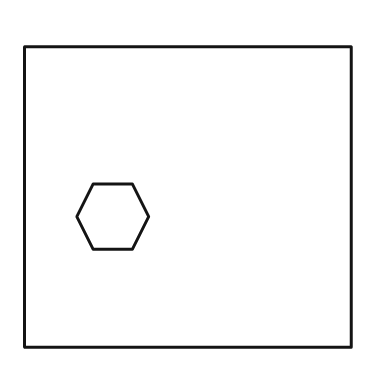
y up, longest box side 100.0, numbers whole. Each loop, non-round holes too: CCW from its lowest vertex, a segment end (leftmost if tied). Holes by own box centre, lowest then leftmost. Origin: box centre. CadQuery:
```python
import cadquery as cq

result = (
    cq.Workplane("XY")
    .moveTo(-50.0, -46.0)
    .lineTo(50.0, -46.0)
    .lineTo(50.0, 46.0)
    .lineTo(-50.0, 46.0)
    .close()
    .moveTo(-29.0, -16.0)
    .lineTo(-17.0, -16.0)
    .lineTo(-12.0, -6.0)
    .lineTo(-17.0, 4.0)
    .lineTo(-29.0, 4.0)
    .lineTo(-34.0, -6.0)
    .close()
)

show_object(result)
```